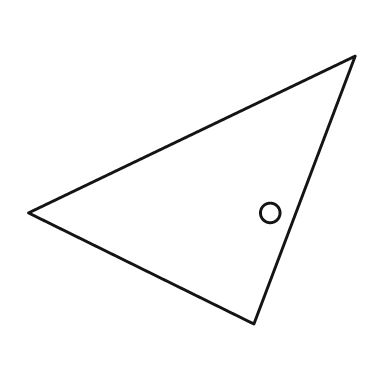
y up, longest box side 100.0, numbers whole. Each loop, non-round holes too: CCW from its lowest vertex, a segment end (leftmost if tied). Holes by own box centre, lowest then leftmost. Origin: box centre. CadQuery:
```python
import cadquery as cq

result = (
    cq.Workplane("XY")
    .moveTo(19.0, -41.0)
    .lineTo(50.0, 41.0)
    .lineTo(-50.0, -7.0)
    .close()
    .moveTo(24.0, -7.0)
    .circle(3.0)
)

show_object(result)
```